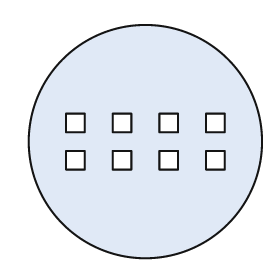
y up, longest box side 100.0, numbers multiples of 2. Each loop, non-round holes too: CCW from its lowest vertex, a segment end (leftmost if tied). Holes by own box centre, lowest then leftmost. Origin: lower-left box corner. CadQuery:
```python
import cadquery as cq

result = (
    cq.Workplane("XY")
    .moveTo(50.0, 50.0)
    .circle(50.0)
    .moveTo(16.0, 38.0)
    .lineTo(24.0, 38.0)
    .lineTo(24.0, 46.0)
    .lineTo(16.0, 46.0)
    .close()
    .moveTo(36.0, 38.0)
    .lineTo(44.0, 38.0)
    .lineTo(44.0, 46.0)
    .lineTo(36.0, 46.0)
    .close()
    .moveTo(56.0, 38.0)
    .lineTo(64.0, 38.0)
    .lineTo(64.0, 46.0)
    .lineTo(56.0, 46.0)
    .close()
    .moveTo(76.0, 38.0)
    .lineTo(84.0, 38.0)
    .lineTo(84.0, 46.0)
    .lineTo(76.0, 46.0)
    .close()
    .moveTo(16.0, 54.0)
    .lineTo(24.0, 54.0)
    .lineTo(24.0, 62.0)
    .lineTo(16.0, 62.0)
    .close()
    .moveTo(36.0, 54.0)
    .lineTo(44.0, 54.0)
    .lineTo(44.0, 62.0)
    .lineTo(36.0, 62.0)
    .close()
    .moveTo(56.0, 54.0)
    .lineTo(64.0, 54.0)
    .lineTo(64.0, 62.0)
    .lineTo(56.0, 62.0)
    .close()
    .moveTo(76.0, 54.0)
    .lineTo(84.0, 54.0)
    .lineTo(84.0, 62.0)
    .lineTo(76.0, 62.0)
    .close()
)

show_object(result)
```